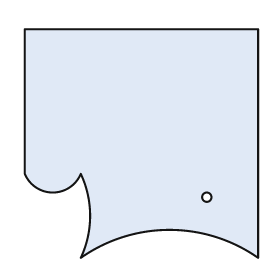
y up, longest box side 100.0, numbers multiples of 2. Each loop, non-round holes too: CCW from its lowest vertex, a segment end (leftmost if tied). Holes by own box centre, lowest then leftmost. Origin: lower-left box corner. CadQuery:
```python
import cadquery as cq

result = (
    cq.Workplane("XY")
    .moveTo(24.0, 0.0)
    .threePointArc((62.0, 12.0), (100.0, 0.0))
    .lineTo(100.0, 98.0)
    .lineTo(0.0, 98.0)
    .lineTo(0.0, 36.0)
    .threePointArc((12.0, 28.0), (24.0, 36.0))
    .threePointArc((28.0, 18.0), (24.0, 0.0))
    .close()
    .moveTo(78.0, 26.0)
    .circle(2.0)
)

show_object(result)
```